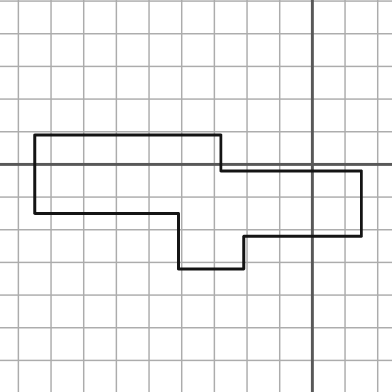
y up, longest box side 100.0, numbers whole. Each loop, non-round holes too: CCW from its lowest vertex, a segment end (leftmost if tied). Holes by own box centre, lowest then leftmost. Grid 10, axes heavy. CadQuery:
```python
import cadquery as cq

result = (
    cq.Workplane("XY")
    .moveTo(-41.0, -32.0)
    .lineTo(-21.0, -32.0)
    .lineTo(-21.0, -22.0)
    .lineTo(15.0, -22.0)
    .lineTo(15.0, -2.0)
    .lineTo(-28.0, -2.0)
    .lineTo(-28.0, 9.0)
    .lineTo(-85.0, 9.0)
    .lineTo(-85.0, -15.0)
    .lineTo(-41.0, -15.0)
    .close()
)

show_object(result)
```